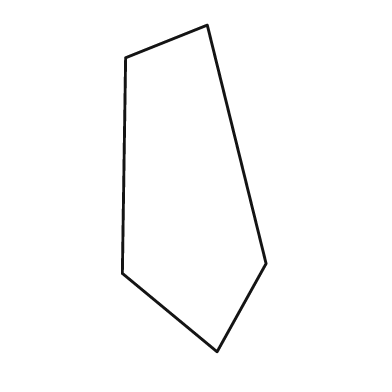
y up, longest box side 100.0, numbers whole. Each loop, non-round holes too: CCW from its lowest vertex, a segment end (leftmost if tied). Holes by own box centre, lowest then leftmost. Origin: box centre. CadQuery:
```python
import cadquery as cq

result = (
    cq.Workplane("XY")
    .moveTo(7.0, -50.0)
    .lineTo(22.0, -23.0)
    .lineTo(4.0, 50.0)
    .lineTo(-21.0, 40.0)
    .lineTo(-22.0, -26.0)
    .close()
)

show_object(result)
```